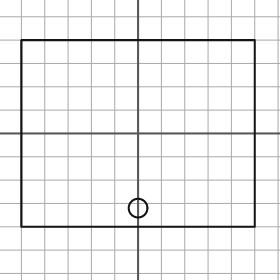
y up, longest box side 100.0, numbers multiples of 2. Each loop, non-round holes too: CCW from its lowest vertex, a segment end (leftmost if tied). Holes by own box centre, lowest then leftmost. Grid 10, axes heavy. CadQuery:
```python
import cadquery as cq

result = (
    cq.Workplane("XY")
    .moveTo(-50.0, -40.0)
    .lineTo(50.0, -40.0)
    .lineTo(50.0, 40.0)
    .lineTo(-50.0, 40.0)
    .close()
    .moveTo(0.0, -32.0)
    .circle(4.0)
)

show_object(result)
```